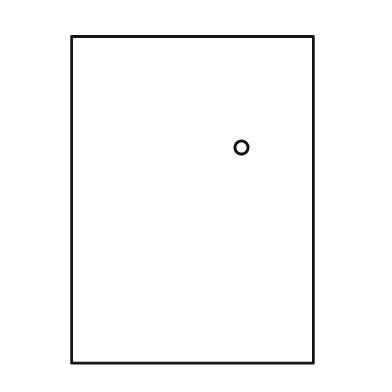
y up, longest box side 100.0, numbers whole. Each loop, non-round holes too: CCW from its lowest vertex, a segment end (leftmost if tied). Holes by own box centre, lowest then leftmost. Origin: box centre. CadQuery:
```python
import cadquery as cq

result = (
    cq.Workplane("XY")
    .moveTo(-37.0, -50.0)
    .lineTo(37.0, -50.0)
    .lineTo(37.0, 50.0)
    .lineTo(-37.0, 50.0)
    .close()
    .moveTo(15.0, 16.0)
    .circle(2.0)
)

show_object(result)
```